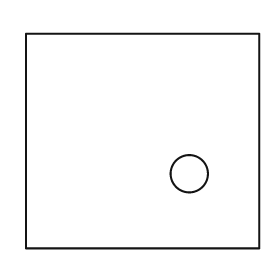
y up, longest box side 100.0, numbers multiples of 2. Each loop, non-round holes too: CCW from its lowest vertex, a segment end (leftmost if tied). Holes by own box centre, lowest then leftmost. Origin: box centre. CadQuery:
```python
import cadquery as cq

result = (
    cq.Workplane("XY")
    .moveTo(-50.0, -46.0)
    .lineTo(50.0, -46.0)
    .lineTo(50.0, 46.0)
    .lineTo(-50.0, 46.0)
    .close()
    .moveTo(20.0, -14.0)
    .circle(8.0)
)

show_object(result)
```